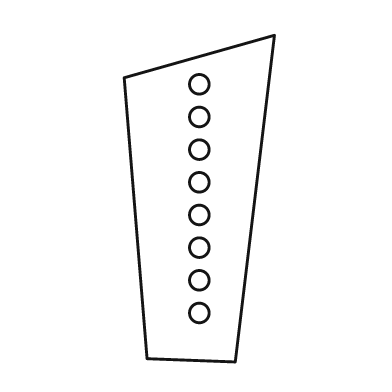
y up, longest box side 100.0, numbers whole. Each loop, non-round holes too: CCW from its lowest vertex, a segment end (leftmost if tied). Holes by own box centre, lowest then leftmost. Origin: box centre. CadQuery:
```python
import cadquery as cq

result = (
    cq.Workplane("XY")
    .moveTo(11.0, -50.0)
    .lineTo(23.0, 50.0)
    .lineTo(-23.0, 37.0)
    .lineTo(-16.0, -49.0)
    .close()
    .moveTo(0.0, -35.0)
    .circle(3.0)
    .moveTo(0.0, -25.0)
    .circle(3.0)
    .moveTo(0.0, -15.0)
    .circle(3.0)
    .moveTo(0.0, -5.0)
    .circle(3.0)
    .moveTo(0.0, 5.0)
    .circle(3.0)
    .moveTo(0.0, 15.0)
    .circle(3.0)
    .moveTo(0.0, 25.0)
    .circle(3.0)
    .moveTo(0.0, 35.0)
    .circle(3.0)
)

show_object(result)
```